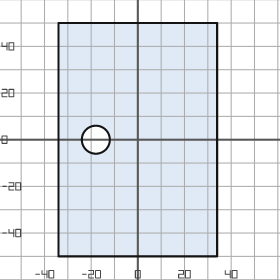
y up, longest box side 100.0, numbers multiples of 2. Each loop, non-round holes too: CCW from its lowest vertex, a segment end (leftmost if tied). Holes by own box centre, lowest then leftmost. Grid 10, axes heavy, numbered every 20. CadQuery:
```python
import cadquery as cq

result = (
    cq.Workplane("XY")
    .moveTo(-34.0, -50.0)
    .lineTo(34.0, -50.0)
    .lineTo(34.0, 50.0)
    .lineTo(-34.0, 50.0)
    .close()
    .moveTo(-18.0, 0.0)
    .circle(6.0)
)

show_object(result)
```